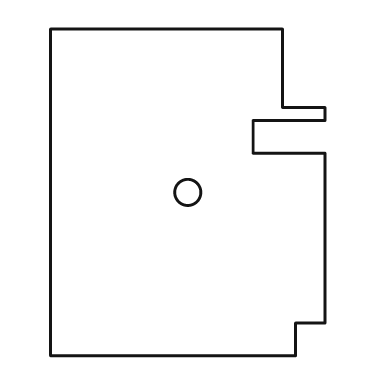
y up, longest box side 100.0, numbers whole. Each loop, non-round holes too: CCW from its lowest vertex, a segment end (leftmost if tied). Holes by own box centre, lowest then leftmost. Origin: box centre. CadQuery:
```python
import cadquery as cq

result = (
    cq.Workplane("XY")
    .moveTo(-42.0, -50.0)
    .lineTo(33.0, -50.0)
    .lineTo(33.0, -40.0)
    .lineTo(42.0, -40.0)
    .lineTo(42.0, 12.0)
    .lineTo(20.0, 12.0)
    .lineTo(20.0, 22.0)
    .lineTo(42.0, 22.0)
    .lineTo(42.0, 26.0)
    .lineTo(29.0, 26.0)
    .lineTo(29.0, 50.0)
    .lineTo(-42.0, 50.0)
    .close()
    .moveTo(0.0, 0.0)
    .circle(4.0)
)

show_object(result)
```